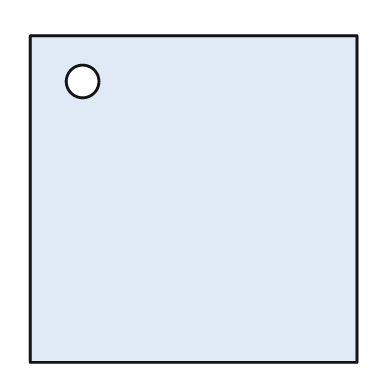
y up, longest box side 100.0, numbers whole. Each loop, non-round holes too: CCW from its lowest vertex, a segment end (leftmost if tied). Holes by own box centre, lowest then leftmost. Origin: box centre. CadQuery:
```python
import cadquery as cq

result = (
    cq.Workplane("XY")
    .moveTo(-50.0, -50.0)
    .lineTo(50.0, -50.0)
    .lineTo(50.0, 50.0)
    .lineTo(-50.0, 50.0)
    .close()
    .moveTo(-34.0, 36.0)
    .circle(5.0)
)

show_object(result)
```